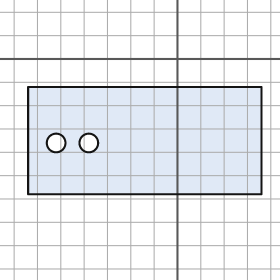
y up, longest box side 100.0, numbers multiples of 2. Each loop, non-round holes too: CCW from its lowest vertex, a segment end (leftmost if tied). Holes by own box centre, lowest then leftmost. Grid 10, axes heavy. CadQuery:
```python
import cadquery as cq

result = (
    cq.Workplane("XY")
    .moveTo(-64.0, -58.0)
    .lineTo(36.0, -58.0)
    .lineTo(36.0, -12.0)
    .lineTo(-64.0, -12.0)
    .close()
    .moveTo(-52.0, -36.0)
    .circle(4.0)
    .moveTo(-38.0, -36.0)
    .circle(4.0)
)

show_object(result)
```